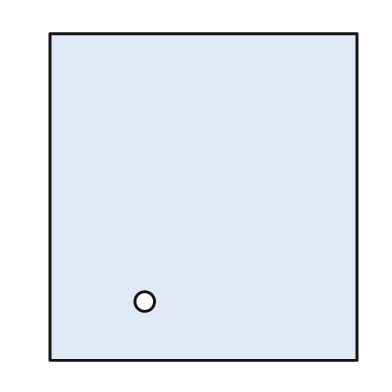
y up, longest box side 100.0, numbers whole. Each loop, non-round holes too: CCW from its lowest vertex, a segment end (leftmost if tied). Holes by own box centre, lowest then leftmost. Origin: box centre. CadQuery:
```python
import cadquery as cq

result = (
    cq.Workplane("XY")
    .moveTo(-47.0, -50.0)
    .lineTo(47.0, -50.0)
    .lineTo(47.0, 50.0)
    .lineTo(-47.0, 50.0)
    .close()
    .moveTo(-18.0, -32.0)
    .circle(3.0)
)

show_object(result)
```